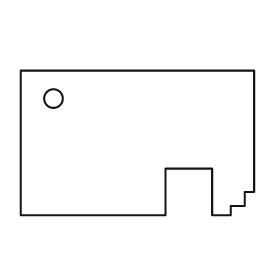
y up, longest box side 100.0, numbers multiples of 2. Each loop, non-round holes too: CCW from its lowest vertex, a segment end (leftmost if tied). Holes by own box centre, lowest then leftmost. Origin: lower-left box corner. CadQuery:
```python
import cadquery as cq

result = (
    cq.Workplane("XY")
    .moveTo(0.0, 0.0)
    .lineTo(62.0, 0.0)
    .lineTo(62.0, 20.0)
    .lineTo(82.0, 20.0)
    .lineTo(82.0, 0.0)
    .lineTo(90.0, 0.0)
    .lineTo(90.0, 4.0)
    .lineTo(96.0, 4.0)
    .lineTo(96.0, 10.0)
    .lineTo(100.0, 10.0)
    .lineTo(100.0, 62.0)
    .lineTo(0.0, 62.0)
    .close()
    .moveTo(14.0, 50.0)
    .circle(4.0)
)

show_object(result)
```